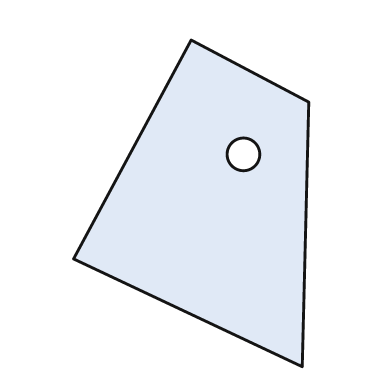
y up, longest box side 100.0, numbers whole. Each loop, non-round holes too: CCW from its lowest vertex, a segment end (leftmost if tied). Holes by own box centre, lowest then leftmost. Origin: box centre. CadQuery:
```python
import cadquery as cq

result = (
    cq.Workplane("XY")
    .moveTo(34.0, -50.0)
    .lineTo(36.0, 31.0)
    .lineTo(0.0, 50.0)
    .lineTo(-36.0, -17.0)
    .close()
    .moveTo(16.0, 15.0)
    .circle(5.0)
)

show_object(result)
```